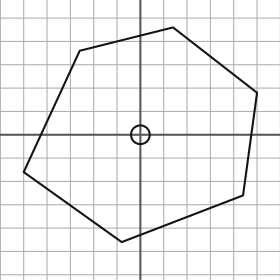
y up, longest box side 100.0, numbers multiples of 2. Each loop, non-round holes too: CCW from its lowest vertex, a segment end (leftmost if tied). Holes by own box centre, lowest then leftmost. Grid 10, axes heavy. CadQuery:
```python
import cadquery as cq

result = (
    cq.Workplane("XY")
    .moveTo(-8.0, -46.0)
    .lineTo(44.0, -26.0)
    .lineTo(50.0, 18.0)
    .lineTo(14.0, 46.0)
    .lineTo(-26.0, 36.0)
    .lineTo(-50.0, -16.0)
    .close()
    .moveTo(0.0, 0.0)
    .circle(4.0)
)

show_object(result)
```